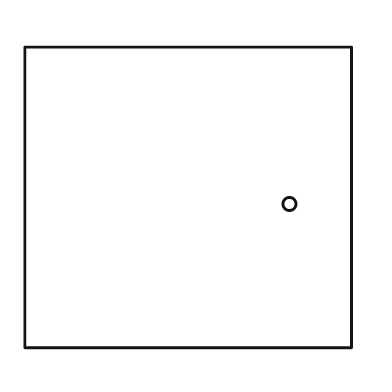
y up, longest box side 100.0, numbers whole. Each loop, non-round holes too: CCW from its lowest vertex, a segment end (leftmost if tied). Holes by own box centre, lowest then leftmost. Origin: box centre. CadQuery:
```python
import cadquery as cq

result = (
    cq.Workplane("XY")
    .moveTo(-50.0, -46.0)
    .lineTo(50.0, -46.0)
    .lineTo(50.0, 46.0)
    .lineTo(-50.0, 46.0)
    .close()
    .moveTo(31.0, -2.0)
    .circle(2.0)
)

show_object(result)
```